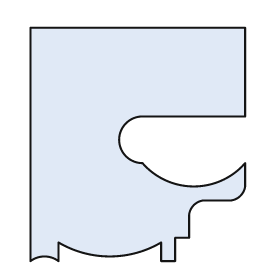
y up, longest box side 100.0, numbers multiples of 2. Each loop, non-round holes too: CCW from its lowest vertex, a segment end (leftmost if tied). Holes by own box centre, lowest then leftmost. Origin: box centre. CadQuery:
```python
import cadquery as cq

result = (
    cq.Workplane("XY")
    .moveTo(-46.0, -50.0)
    .threePointArc((-40.0, -48.0), (-34.0, -50.0))
    .lineTo(-34.0, -42.0)
    .threePointArc((-12.0, -48.0), (10.0, -42.0))
    .lineTo(10.0, -50.0)
    .lineTo(16.0, -50.0)
    .lineTo(16.0, -40.0)
    .lineTo(22.0, -40.0)
    .lineTo(22.0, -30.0)
    .threePointArc((24.0, -26.0), (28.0, -24.0))
    .lineTo(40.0, -24.0)
    .threePointArc((44.0, -22.0), (46.0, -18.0))
    .lineTo(46.0, -8.0)
    .threePointArc((24.0, -18.0), (2.0, -8.0))
    .threePointArc((-8.0, 2.0), (2.0, 12.0))
    .lineTo(46.0, 12.0)
    .lineTo(46.0, 50.0)
    .lineTo(-46.0, 50.0)
    .close()
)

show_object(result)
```